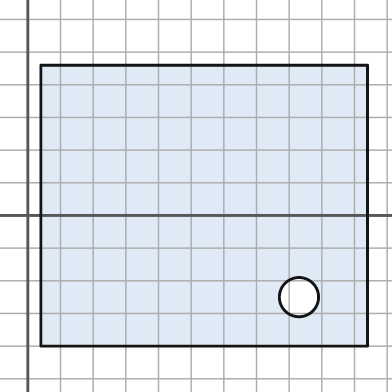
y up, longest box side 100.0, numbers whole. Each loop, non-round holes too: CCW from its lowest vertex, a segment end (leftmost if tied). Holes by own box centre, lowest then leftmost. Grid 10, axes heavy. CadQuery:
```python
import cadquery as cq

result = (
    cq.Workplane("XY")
    .moveTo(4.0, -40.0)
    .lineTo(104.0, -40.0)
    .lineTo(104.0, 46.0)
    .lineTo(4.0, 46.0)
    .close()
    .moveTo(83.0, -25.0)
    .circle(6.0)
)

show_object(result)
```